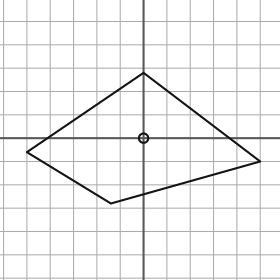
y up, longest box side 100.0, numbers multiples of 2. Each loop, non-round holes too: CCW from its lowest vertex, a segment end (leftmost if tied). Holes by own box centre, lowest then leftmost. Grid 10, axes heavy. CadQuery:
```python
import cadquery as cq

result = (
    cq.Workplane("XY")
    .moveTo(-14.0, -28.0)
    .lineTo(50.0, -10.0)
    .lineTo(0.0, 28.0)
    .lineTo(-50.0, -6.0)
    .close()
    .moveTo(0.0, 0.0)
    .circle(2.0)
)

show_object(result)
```